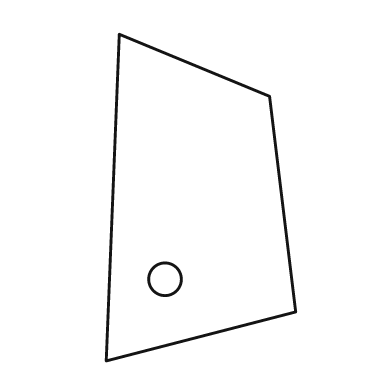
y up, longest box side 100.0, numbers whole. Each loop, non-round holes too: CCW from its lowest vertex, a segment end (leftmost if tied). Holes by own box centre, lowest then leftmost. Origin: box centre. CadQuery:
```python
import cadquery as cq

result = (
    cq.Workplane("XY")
    .moveTo(-29.0, -50.0)
    .lineTo(29.0, -35.0)
    .lineTo(21.0, 31.0)
    .lineTo(-25.0, 50.0)
    .close()
    .moveTo(-11.0, -25.0)
    .circle(5.0)
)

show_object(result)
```